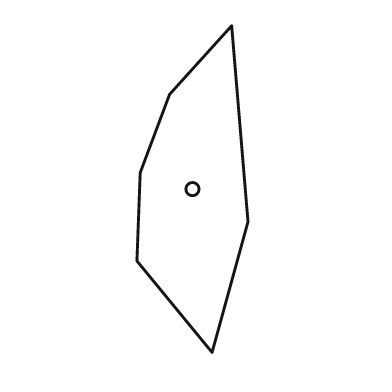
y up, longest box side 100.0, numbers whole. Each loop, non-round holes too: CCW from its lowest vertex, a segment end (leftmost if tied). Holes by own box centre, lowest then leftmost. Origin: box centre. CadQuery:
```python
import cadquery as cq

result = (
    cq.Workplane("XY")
    .moveTo(6.0, -50.0)
    .lineTo(17.0, -10.0)
    .lineTo(12.0, 50.0)
    .lineTo(-7.0, 29.0)
    .lineTo(-16.0, 5.0)
    .lineTo(-17.0, -22.0)
    .close()
    .moveTo(0.0, 0.0)
    .circle(2.0)
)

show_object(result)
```